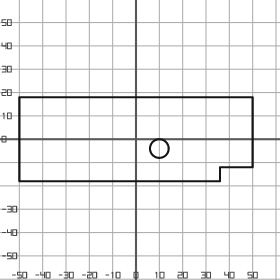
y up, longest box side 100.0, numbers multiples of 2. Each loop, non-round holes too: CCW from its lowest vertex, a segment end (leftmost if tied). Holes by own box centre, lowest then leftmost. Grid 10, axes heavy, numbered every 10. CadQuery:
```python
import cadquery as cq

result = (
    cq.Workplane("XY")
    .moveTo(-50.0, -18.0)
    .lineTo(36.0, -18.0)
    .lineTo(36.0, -12.0)
    .lineTo(50.0, -12.0)
    .lineTo(50.0, 18.0)
    .lineTo(-50.0, 18.0)
    .close()
    .moveTo(10.0, -4.0)
    .circle(4.0)
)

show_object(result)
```